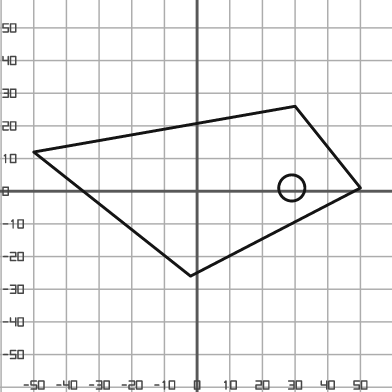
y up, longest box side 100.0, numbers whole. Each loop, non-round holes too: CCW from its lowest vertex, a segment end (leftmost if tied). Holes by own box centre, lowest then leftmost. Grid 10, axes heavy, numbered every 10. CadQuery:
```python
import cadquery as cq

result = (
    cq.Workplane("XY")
    .moveTo(-2.0, -26.0)
    .lineTo(50.0, 1.0)
    .lineTo(30.0, 26.0)
    .lineTo(-50.0, 12.0)
    .close()
    .moveTo(29.0, 1.0)
    .circle(4.0)
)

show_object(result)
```